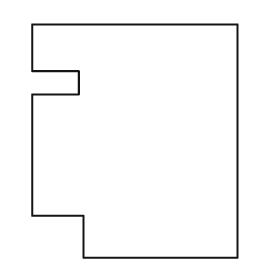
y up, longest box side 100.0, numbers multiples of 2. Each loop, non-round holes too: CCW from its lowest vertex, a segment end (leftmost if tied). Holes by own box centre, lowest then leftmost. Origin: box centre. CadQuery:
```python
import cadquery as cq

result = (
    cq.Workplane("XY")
    .moveTo(-22.0, -50.0)
    .lineTo(44.0, -50.0)
    .lineTo(44.0, 50.0)
    .lineTo(-44.0, 50.0)
    .lineTo(-44.0, 30.0)
    .lineTo(-24.0, 30.0)
    .lineTo(-24.0, 20.0)
    .lineTo(-44.0, 20.0)
    .lineTo(-44.0, -32.0)
    .lineTo(-22.0, -32.0)
    .close()
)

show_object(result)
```